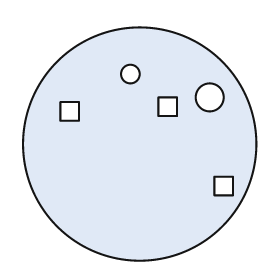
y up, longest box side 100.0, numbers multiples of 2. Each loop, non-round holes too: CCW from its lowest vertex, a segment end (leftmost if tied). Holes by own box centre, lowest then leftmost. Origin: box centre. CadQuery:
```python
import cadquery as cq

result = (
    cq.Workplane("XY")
    .moveTo(0.0, 0.0)
    .circle(50.0)
    .moveTo(32.0, -22.0)
    .lineTo(40.0, -22.0)
    .lineTo(40.0, -14.0)
    .lineTo(32.0, -14.0)
    .close()
    .moveTo(-34.0, 10.0)
    .lineTo(-26.0, 10.0)
    .lineTo(-26.0, 18.0)
    .lineTo(-34.0, 18.0)
    .close()
    .moveTo(8.0, 12.0)
    .lineTo(16.0, 12.0)
    .lineTo(16.0, 20.0)
    .lineTo(8.0, 20.0)
    .close()
    .moveTo(30.0, 20.0)
    .circle(6.0)
    .moveTo(-4.0, 30.0)
    .circle(4.0)
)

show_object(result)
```